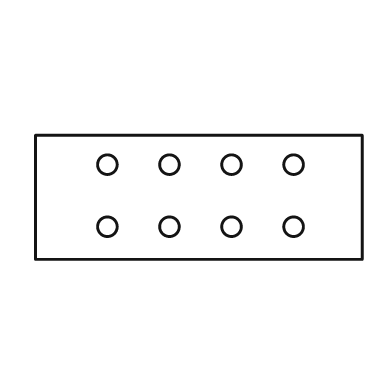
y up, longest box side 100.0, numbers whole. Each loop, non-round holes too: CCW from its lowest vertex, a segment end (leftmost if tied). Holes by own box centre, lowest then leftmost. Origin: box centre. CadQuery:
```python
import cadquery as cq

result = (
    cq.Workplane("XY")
    .moveTo(-50.0, -19.0)
    .lineTo(50.0, -19.0)
    .lineTo(50.0, 19.0)
    .lineTo(-50.0, 19.0)
    .close()
    .moveTo(-28.0, -9.0)
    .circle(3.0)
    .moveTo(-9.0, -9.0)
    .circle(3.0)
    .moveTo(10.0, -9.0)
    .circle(3.0)
    .moveTo(29.0, -9.0)
    .circle(3.0)
    .moveTo(-28.0, 10.0)
    .circle(3.0)
    .moveTo(-9.0, 10.0)
    .circle(3.0)
    .moveTo(10.0, 10.0)
    .circle(3.0)
    .moveTo(29.0, 10.0)
    .circle(3.0)
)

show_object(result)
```